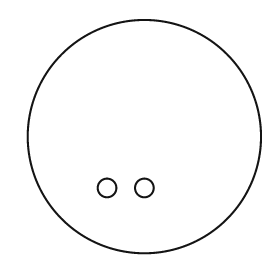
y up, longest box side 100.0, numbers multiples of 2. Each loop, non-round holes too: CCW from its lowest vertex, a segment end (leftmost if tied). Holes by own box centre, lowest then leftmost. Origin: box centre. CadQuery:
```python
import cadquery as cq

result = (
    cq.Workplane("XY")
    .moveTo(0.0, 0.0)
    .circle(50.0)
    .moveTo(-16.0, -22.0)
    .circle(4.0)
    .moveTo(0.0, -22.0)
    .circle(4.0)
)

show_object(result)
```